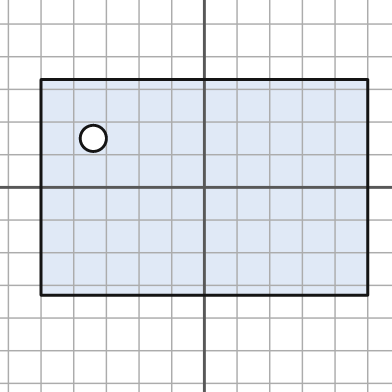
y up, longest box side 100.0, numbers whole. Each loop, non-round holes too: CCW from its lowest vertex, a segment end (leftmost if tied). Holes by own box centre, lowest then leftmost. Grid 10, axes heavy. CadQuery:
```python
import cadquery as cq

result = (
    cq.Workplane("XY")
    .moveTo(-50.0, -33.0)
    .lineTo(50.0, -33.0)
    .lineTo(50.0, 33.0)
    .lineTo(-50.0, 33.0)
    .close()
    .moveTo(-34.0, 15.0)
    .circle(4.0)
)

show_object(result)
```